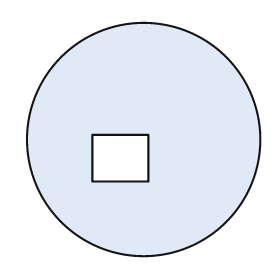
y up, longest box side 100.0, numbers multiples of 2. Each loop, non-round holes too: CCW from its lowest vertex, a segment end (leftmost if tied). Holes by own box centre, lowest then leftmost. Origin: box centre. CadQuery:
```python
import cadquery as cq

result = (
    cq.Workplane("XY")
    .moveTo(0.0, 0.0)
    .circle(50.0)
    .moveTo(-22.0, -18.0)
    .lineTo(2.0, -18.0)
    .lineTo(2.0, 2.0)
    .lineTo(-22.0, 2.0)
    .close()
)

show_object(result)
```